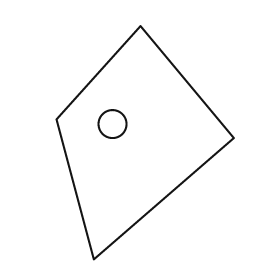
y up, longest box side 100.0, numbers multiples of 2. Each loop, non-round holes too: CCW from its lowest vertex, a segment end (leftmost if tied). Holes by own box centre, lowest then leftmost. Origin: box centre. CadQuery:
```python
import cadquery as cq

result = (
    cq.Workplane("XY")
    .moveTo(-22.0, -50.0)
    .lineTo(38.0, 2.0)
    .lineTo(-2.0, 50.0)
    .lineTo(-38.0, 10.0)
    .close()
    .moveTo(-14.0, 8.0)
    .circle(6.0)
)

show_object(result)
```